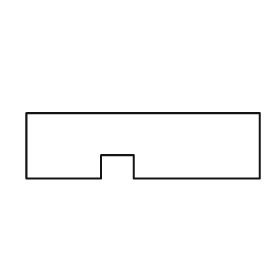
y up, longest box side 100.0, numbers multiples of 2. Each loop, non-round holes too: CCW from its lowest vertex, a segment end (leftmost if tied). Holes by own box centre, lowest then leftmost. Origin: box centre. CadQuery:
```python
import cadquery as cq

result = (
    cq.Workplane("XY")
    .moveTo(-50.0, -14.0)
    .lineTo(-18.0, -14.0)
    .lineTo(-18.0, -4.0)
    .lineTo(-4.0, -4.0)
    .lineTo(-4.0, -14.0)
    .lineTo(50.0, -14.0)
    .lineTo(50.0, 14.0)
    .lineTo(-50.0, 14.0)
    .close()
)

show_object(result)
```